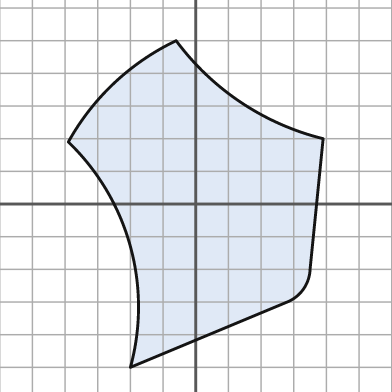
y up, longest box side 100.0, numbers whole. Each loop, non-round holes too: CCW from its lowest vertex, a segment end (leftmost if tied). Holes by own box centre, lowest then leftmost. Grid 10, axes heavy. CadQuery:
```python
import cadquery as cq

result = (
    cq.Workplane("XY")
    .moveTo(-20.0, -50.0)
    .lineTo(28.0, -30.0)
    .threePointArc((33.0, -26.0), (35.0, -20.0))
    .lineTo(39.0, 20.0)
    .threePointArc((14.0, 31.0), (-6.0, 50.0))
    .threePointArc((-25.0, 37.0), (-39.0, 19.0))
    .threePointArc((-20.0, -13.0), (-20.0, -50.0))
    .close()
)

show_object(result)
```